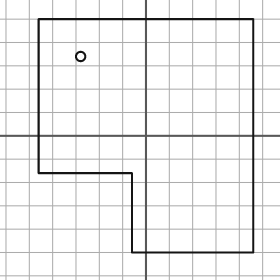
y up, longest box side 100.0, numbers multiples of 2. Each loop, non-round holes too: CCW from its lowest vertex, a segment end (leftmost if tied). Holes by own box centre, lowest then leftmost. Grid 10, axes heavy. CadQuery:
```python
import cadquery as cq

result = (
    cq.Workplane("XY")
    .moveTo(-6.0, -50.0)
    .lineTo(46.0, -50.0)
    .lineTo(46.0, 50.0)
    .lineTo(-46.0, 50.0)
    .lineTo(-46.0, -16.0)
    .lineTo(-6.0, -16.0)
    .close()
    .moveTo(-28.0, 34.0)
    .circle(2.0)
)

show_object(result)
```